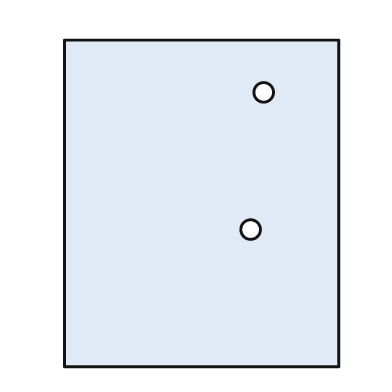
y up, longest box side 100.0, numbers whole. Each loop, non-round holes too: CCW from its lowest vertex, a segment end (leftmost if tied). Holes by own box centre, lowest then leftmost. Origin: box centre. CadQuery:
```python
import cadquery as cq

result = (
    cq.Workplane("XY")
    .moveTo(-42.0, -50.0)
    .lineTo(42.0, -50.0)
    .lineTo(42.0, 50.0)
    .lineTo(-42.0, 50.0)
    .close()
    .moveTo(15.0, -8.0)
    .circle(3.0)
    .moveTo(19.0, 34.0)
    .circle(3.0)
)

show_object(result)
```